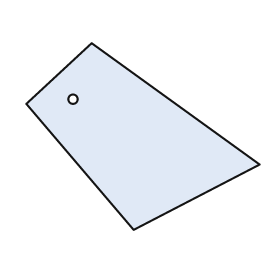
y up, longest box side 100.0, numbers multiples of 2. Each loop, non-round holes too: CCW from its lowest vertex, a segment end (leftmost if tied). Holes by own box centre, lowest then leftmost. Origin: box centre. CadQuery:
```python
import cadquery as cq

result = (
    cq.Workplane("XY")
    .moveTo(-4.0, -40.0)
    .lineTo(50.0, -12.0)
    .lineTo(-22.0, 40.0)
    .lineTo(-50.0, 14.0)
    .close()
    .moveTo(-30.0, 16.0)
    .circle(2.0)
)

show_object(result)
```